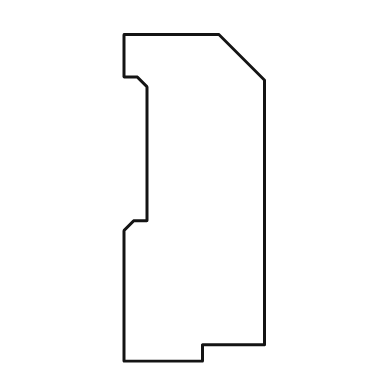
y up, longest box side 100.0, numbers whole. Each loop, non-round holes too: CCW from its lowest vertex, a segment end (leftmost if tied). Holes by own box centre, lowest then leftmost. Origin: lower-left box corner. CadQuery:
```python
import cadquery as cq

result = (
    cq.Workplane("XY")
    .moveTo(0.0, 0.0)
    .lineTo(24.0, 0.0)
    .lineTo(24.0, 5.0)
    .lineTo(43.0, 5.0)
    .lineTo(43.0, 86.0)
    .lineTo(29.0, 100.0)
    .lineTo(0.0, 100.0)
    .lineTo(0.0, 87.0)
    .lineTo(4.0, 87.0)
    .lineTo(7.0, 84.0)
    .lineTo(7.0, 43.0)
    .lineTo(3.0, 43.0)
    .lineTo(0.0, 40.0)
    .close()
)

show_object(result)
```